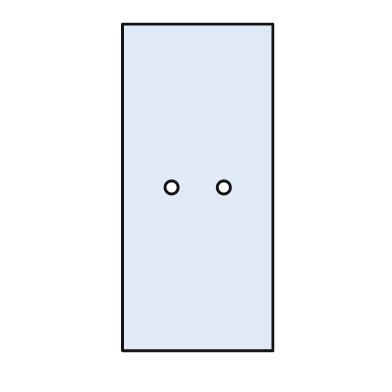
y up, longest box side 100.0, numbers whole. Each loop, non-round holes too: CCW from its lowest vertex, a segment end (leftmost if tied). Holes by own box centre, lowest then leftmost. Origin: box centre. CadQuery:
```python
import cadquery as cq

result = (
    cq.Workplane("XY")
    .moveTo(-23.0, -50.0)
    .lineTo(23.0, -50.0)
    .lineTo(23.0, 50.0)
    .lineTo(-23.0, 50.0)
    .close()
    .moveTo(-8.0, 0.0)
    .circle(2.0)
    .moveTo(8.0, 0.0)
    .circle(2.0)
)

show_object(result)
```